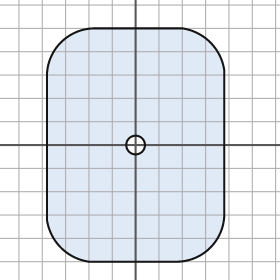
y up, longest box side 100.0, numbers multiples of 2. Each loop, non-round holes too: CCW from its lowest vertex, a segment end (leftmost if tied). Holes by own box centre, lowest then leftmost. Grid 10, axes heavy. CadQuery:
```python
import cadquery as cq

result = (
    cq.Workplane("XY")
    .moveTo(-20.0, -50.0)
    .lineTo(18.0, -50.0)
    .threePointArc((32.0, -44.0), (38.0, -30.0))
    .lineTo(38.0, 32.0)
    .threePointArc((32.0, 44.0), (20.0, 50.0))
    .lineTo(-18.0, 50.0)
    .threePointArc((-32.0, 44.0), (-38.0, 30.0))
    .lineTo(-38.0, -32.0)
    .threePointArc((-32.0, -44.0), (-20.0, -50.0))
    .close()
    .moveTo(0.0, 0.0)
    .circle(4.0)
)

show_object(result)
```